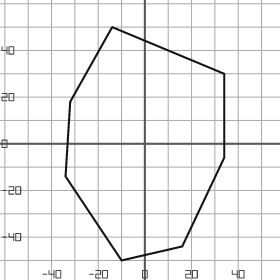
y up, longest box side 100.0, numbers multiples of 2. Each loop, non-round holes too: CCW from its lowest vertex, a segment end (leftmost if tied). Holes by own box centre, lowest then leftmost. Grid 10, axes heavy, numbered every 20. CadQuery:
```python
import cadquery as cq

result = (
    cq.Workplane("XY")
    .moveTo(-10.0, -50.0)
    .lineTo(16.0, -44.0)
    .lineTo(34.0, -6.0)
    .lineTo(34.0, 30.0)
    .lineTo(-14.0, 50.0)
    .lineTo(-32.0, 18.0)
    .lineTo(-34.0, -14.0)
    .close()
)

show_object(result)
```